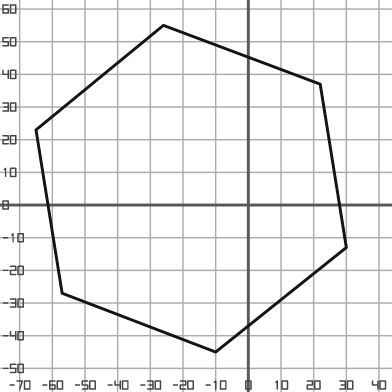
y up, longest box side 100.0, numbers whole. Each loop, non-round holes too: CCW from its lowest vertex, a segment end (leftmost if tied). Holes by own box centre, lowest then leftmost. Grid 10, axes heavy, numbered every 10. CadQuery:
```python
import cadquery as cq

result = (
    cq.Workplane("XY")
    .moveTo(-10.0, -45.0)
    .lineTo(30.0, -13.0)
    .lineTo(22.0, 37.0)
    .lineTo(-26.0, 55.0)
    .lineTo(-65.0, 23.0)
    .lineTo(-57.0, -27.0)
    .close()
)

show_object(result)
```